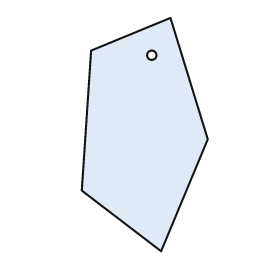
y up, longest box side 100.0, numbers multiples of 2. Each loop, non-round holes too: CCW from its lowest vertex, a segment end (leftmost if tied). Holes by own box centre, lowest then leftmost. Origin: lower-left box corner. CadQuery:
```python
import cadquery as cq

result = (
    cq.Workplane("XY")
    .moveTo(34.0, 0.0)
    .lineTo(54.0, 48.0)
    .lineTo(38.0, 100.0)
    .lineTo(4.0, 86.0)
    .lineTo(0.0, 26.0)
    .close()
    .moveTo(30.0, 84.0)
    .circle(2.0)
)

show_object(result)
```